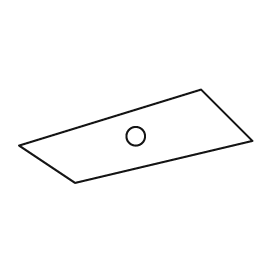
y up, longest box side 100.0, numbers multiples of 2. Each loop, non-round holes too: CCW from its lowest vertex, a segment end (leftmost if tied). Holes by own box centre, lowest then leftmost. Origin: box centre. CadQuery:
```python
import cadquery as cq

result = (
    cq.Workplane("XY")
    .moveTo(-26.0, -20.0)
    .lineTo(50.0, -2.0)
    .lineTo(28.0, 20.0)
    .lineTo(-50.0, -4.0)
    .close()
    .moveTo(0.0, 0.0)
    .circle(4.0)
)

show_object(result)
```